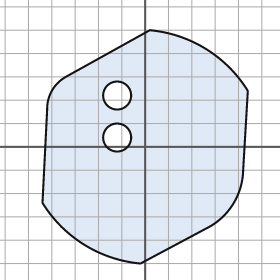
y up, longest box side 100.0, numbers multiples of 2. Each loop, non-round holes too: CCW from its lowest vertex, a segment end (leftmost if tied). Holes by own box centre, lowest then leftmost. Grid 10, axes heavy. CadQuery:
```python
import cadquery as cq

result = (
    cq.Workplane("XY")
    .moveTo(-2.0, -50.0)
    .lineTo(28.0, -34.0)
    .threePointArc((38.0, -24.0), (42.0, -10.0))
    .lineTo(44.0, 24.0)
    .threePointArc((26.0, 42.0), (2.0, 50.0))
    .lineTo(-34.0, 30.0)
    .threePointArc((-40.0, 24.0), (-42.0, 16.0))
    .lineTo(-44.0, -24.0)
    .threePointArc((-26.0, -42.0), (-2.0, -50.0))
    .close()
    .moveTo(-12.0, 4.0)
    .circle(6.0)
    .moveTo(-12.0, 22.0)
    .circle(6.0)
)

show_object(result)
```